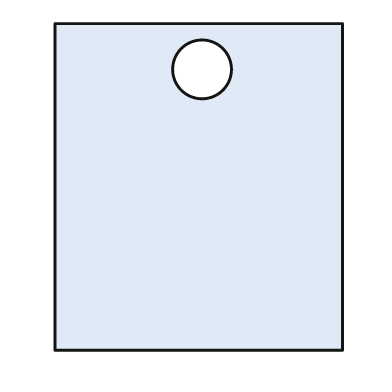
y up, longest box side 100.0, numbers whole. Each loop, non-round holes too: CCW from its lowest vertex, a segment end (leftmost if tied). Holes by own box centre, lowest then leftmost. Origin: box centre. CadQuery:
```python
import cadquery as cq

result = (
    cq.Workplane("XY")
    .moveTo(-44.0, -50.0)
    .lineTo(44.0, -50.0)
    .lineTo(44.0, 50.0)
    .lineTo(-44.0, 50.0)
    .close()
    .moveTo(1.0, 36.0)
    .circle(9.0)
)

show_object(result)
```